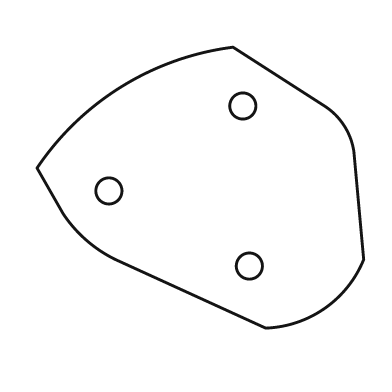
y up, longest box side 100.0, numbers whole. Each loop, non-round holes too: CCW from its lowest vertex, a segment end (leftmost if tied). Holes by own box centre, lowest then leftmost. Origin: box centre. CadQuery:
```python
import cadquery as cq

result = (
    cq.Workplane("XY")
    .moveTo(20.0, -43.0)
    .threePointArc((38.0, -37.0), (50.0, -22.0))
    .lineTo(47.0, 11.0)
    .threePointArc((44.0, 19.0), (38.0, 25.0))
    .lineTo(10.0, 43.0)
    .threePointArc((-24.0, 31.0), (-50.0, 6.0))
    .lineTo(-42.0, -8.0)
    .threePointArc((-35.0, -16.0), (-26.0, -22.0))
    .close()
    .moveTo(15.0, -24.0)
    .circle(4.0)
    .moveTo(-28.0, -1.0)
    .circle(4.0)
    .moveTo(13.0, 25.0)
    .circle(4.0)
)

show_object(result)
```